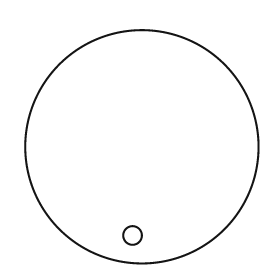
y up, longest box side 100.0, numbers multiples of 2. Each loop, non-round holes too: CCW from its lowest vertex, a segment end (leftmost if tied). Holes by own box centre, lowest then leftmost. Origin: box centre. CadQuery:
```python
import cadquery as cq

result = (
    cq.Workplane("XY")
    .moveTo(0.0, 0.0)
    .circle(50.0)
    .moveTo(-4.0, -38.0)
    .circle(4.0)
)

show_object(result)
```